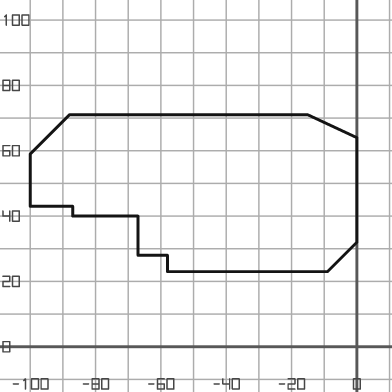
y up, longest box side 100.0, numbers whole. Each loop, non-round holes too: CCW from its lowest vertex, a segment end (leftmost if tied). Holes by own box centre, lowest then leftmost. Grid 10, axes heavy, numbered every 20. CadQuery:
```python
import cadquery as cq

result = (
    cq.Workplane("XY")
    .moveTo(-58.0, 23.0)
    .lineTo(-9.0, 23.0)
    .lineTo(0.0, 32.0)
    .lineTo(0.0, 64.0)
    .lineTo(-15.0, 71.0)
    .lineTo(-88.0, 71.0)
    .lineTo(-100.0, 59.0)
    .lineTo(-100.0, 43.0)
    .lineTo(-87.0, 43.0)
    .lineTo(-87.0, 40.0)
    .lineTo(-67.0, 40.0)
    .lineTo(-67.0, 28.0)
    .lineTo(-58.0, 28.0)
    .close()
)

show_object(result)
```